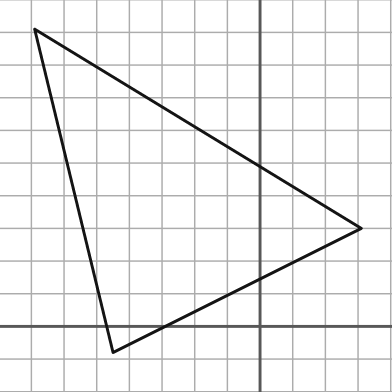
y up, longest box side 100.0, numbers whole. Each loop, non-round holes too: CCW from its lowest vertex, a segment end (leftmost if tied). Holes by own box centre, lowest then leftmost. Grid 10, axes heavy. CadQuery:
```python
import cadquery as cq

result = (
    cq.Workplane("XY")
    .moveTo(-45.0, -8.0)
    .lineTo(31.0, 30.0)
    .lineTo(-69.0, 91.0)
    .close()
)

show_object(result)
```